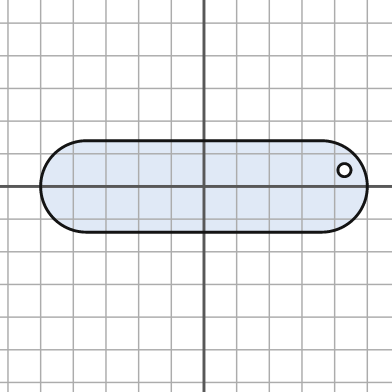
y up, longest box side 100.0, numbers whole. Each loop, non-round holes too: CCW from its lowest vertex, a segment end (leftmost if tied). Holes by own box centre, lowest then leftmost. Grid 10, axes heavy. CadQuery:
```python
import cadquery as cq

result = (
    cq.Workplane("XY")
    .moveTo(-36.0, -14.0)
    .lineTo(36.0, -14.0)
    .threePointArc((50.0, 0.0), (36.0, 14.0))
    .lineTo(-36.0, 14.0)
    .threePointArc((-50.0, 0.0), (-36.0, -14.0))
    .close()
    .moveTo(43.0, 5.0)
    .circle(2.0)
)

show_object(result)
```